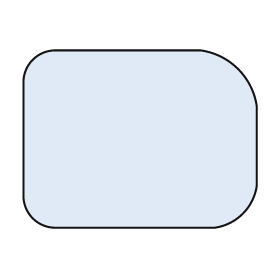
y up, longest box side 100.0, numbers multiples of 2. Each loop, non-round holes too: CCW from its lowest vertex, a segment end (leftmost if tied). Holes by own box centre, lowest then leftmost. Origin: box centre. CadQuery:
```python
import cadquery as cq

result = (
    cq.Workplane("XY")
    .moveTo(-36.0, -38.0)
    .lineTo(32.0, -38.0)
    .threePointArc((44.0, -32.0), (50.0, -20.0))
    .lineTo(50.0, 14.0)
    .threePointArc((42.0, 30.0), (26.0, 38.0))
    .lineTo(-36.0, 38.0)
    .threePointArc((-46.0, 34.0), (-50.0, 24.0))
    .lineTo(-50.0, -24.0)
    .threePointArc((-46.0, -34.0), (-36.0, -38.0))
    .close()
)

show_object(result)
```